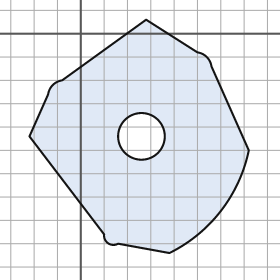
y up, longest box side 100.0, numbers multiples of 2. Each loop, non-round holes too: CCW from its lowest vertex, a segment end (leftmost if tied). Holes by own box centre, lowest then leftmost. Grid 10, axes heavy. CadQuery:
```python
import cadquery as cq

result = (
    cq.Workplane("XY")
    .moveTo(38.0, -94.0)
    .threePointArc((60.0, -76.0), (72.0, -50.0))
    .lineTo(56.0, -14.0)
    .threePointArc((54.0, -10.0), (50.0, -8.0))
    .lineTo(28.0, 6.0)
    .lineTo(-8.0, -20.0)
    .threePointArc((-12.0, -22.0), (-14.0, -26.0))
    .lineTo(-22.0, -44.0)
    .lineTo(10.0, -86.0)
    .threePointArc((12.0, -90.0), (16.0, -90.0))
    .close()
    .moveTo(26.0, -44.0)
    .circle(10.0)
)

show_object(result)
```